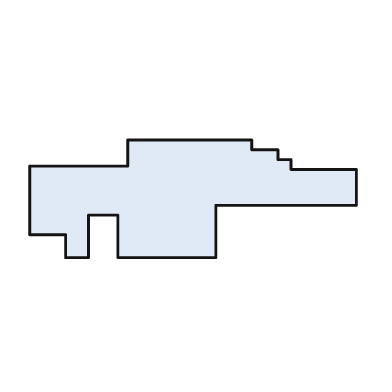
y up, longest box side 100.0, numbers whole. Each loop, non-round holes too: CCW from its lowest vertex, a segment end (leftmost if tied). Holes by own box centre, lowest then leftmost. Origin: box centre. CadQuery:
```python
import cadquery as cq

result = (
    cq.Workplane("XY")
    .moveTo(-39.0, -18.0)
    .lineTo(-32.0, -18.0)
    .lineTo(-32.0, -5.0)
    .lineTo(-23.0, -5.0)
    .lineTo(-23.0, -18.0)
    .lineTo(7.0, -18.0)
    .lineTo(7.0, -2.0)
    .lineTo(50.0, -2.0)
    .lineTo(50.0, 9.0)
    .lineTo(30.0, 9.0)
    .lineTo(30.0, 12.0)
    .lineTo(26.0, 12.0)
    .lineTo(26.0, 15.0)
    .lineTo(18.0, 15.0)
    .lineTo(18.0, 18.0)
    .lineTo(-20.0, 18.0)
    .lineTo(-20.0, 10.0)
    .lineTo(-50.0, 10.0)
    .lineTo(-50.0, -11.0)
    .lineTo(-39.0, -11.0)
    .close()
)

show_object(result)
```